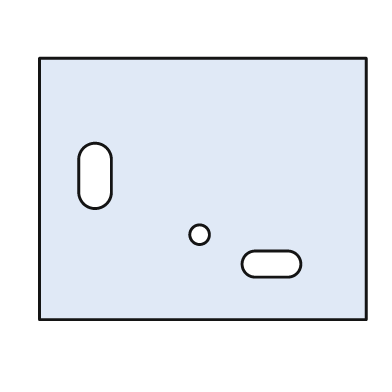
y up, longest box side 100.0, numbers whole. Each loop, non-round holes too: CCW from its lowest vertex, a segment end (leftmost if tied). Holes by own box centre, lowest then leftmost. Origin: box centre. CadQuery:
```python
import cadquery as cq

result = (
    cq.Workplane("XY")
    .moveTo(-50.0, -40.0)
    .lineTo(50.0, -40.0)
    .lineTo(50.0, 40.0)
    .lineTo(-50.0, 40.0)
    .close()
    .moveTo(16.0, -27.0)
    .lineTo(26.0, -27.0)
    .threePointArc((30.0, -23.0), (26.0, -19.0))
    .lineTo(16.0, -19.0)
    .threePointArc((12.0, -23.0), (16.0, -27.0))
    .close()
    .moveTo(-1.0, -14.0)
    .circle(3.0)
    .moveTo(-38.0, -1.0)
    .threePointArc((-33.0, -6.0), (-28.0, -1.0))
    .lineTo(-28.0, 9.0)
    .threePointArc((-33.0, 14.0), (-38.0, 9.0))
    .close()
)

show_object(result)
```